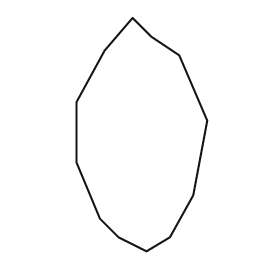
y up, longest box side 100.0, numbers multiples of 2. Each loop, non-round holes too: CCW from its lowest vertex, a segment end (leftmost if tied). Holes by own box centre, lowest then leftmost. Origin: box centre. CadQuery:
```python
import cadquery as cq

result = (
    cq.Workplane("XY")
    .moveTo(2.0, -50.0)
    .lineTo(12.0, -44.0)
    .lineTo(22.0, -26.0)
    .lineTo(28.0, 6.0)
    .lineTo(16.0, 34.0)
    .lineTo(4.0, 42.0)
    .lineTo(-4.0, 50.0)
    .lineTo(-16.0, 36.0)
    .lineTo(-28.0, 14.0)
    .lineTo(-28.0, -12.0)
    .lineTo(-18.0, -36.0)
    .lineTo(-10.0, -44.0)
    .close()
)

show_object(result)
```